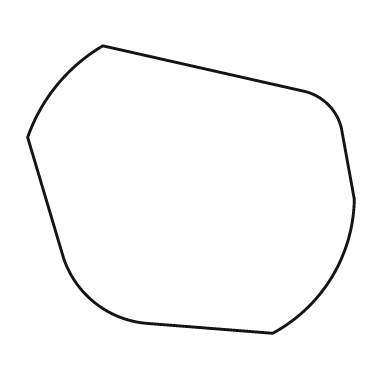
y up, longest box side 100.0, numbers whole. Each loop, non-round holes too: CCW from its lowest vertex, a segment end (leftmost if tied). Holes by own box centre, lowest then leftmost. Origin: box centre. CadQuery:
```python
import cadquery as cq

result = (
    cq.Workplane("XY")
    .moveTo(25.0, -44.0)
    .threePointArc((43.0, -27.0), (50.0, -3.0))
    .lineTo(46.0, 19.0)
    .threePointArc((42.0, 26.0), (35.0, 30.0))
    .lineTo(-27.0, 44.0)
    .threePointArc((-41.0, 32.0), (-50.0, 16.0))
    .lineTo(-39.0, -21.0)
    .threePointArc((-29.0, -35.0), (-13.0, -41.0))
    .close()
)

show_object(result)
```